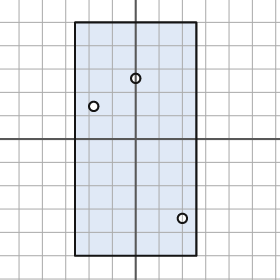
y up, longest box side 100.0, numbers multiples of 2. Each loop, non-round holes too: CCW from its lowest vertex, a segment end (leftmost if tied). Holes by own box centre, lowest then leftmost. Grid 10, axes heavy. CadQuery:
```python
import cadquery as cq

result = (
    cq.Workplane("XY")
    .moveTo(-26.0, -50.0)
    .lineTo(26.0, -50.0)
    .lineTo(26.0, 50.0)
    .lineTo(-26.0, 50.0)
    .close()
    .moveTo(20.0, -34.0)
    .circle(2.0)
    .moveTo(-18.0, 14.0)
    .circle(2.0)
    .moveTo(0.0, 26.0)
    .circle(2.0)
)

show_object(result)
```